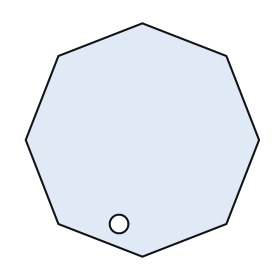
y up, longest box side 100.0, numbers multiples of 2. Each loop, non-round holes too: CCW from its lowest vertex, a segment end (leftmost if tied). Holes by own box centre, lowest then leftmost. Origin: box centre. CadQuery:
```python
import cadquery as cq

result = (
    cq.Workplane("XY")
    .moveTo(0.0, -50.0)
    .lineTo(36.0, -36.0)
    .lineTo(50.0, 0.0)
    .lineTo(36.0, 36.0)
    .lineTo(0.0, 50.0)
    .lineTo(-36.0, 36.0)
    .lineTo(-50.0, 0.0)
    .lineTo(-36.0, -36.0)
    .close()
    .moveTo(-10.0, -36.0)
    .circle(4.0)
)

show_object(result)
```